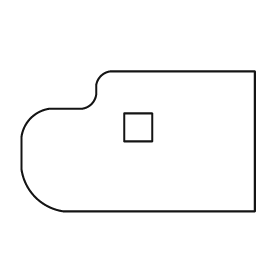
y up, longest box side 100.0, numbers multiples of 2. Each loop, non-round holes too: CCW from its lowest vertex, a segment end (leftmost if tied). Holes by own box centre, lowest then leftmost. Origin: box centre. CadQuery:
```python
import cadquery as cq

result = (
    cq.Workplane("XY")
    .moveTo(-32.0, -30.0)
    .lineTo(50.0, -30.0)
    .lineTo(50.0, 30.0)
    .lineTo(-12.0, 30.0)
    .threePointArc((-16.0, 28.0), (-18.0, 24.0))
    .lineTo(-18.0, 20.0)
    .threePointArc((-20.0, 16.0), (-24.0, 14.0))
    .lineTo(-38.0, 14.0)
    .threePointArc((-46.0, 10.0), (-50.0, 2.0))
    .lineTo(-50.0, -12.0)
    .threePointArc((-44.0, -24.0), (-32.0, -30.0))
    .close()
    .moveTo(-6.0, 0.0)
    .lineTo(6.0, 0.0)
    .lineTo(6.0, 12.0)
    .lineTo(-6.0, 12.0)
    .close()
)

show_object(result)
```